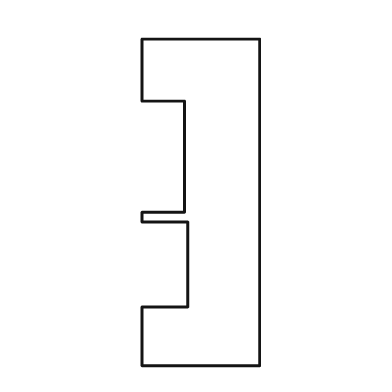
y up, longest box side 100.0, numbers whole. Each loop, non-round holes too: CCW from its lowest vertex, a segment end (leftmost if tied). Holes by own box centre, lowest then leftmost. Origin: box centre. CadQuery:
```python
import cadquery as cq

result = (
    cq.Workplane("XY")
    .moveTo(-18.0, -50.0)
    .lineTo(18.0, -50.0)
    .lineTo(18.0, 50.0)
    .lineTo(-18.0, 50.0)
    .lineTo(-18.0, 31.0)
    .lineTo(-5.0, 31.0)
    .lineTo(-5.0, -3.0)
    .lineTo(-18.0, -3.0)
    .lineTo(-18.0, -6.0)
    .lineTo(-4.0, -6.0)
    .lineTo(-4.0, -32.0)
    .lineTo(-18.0, -32.0)
    .close()
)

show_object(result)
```